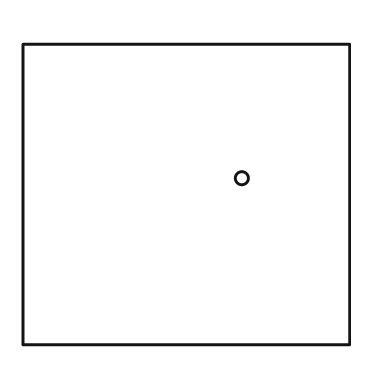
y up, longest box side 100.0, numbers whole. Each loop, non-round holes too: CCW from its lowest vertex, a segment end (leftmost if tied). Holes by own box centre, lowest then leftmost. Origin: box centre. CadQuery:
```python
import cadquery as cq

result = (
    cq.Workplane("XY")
    .moveTo(-50.0, -46.0)
    .lineTo(50.0, -46.0)
    .lineTo(50.0, 46.0)
    .lineTo(-50.0, 46.0)
    .close()
    .moveTo(17.0, 5.0)
    .circle(2.0)
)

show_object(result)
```